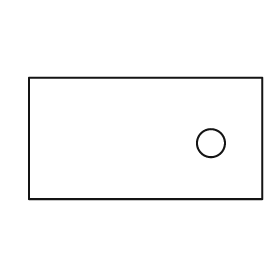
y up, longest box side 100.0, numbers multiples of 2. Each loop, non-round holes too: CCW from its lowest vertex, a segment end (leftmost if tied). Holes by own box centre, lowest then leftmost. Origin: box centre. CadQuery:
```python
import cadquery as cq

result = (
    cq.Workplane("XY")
    .moveTo(-50.0, -26.0)
    .lineTo(50.0, -26.0)
    .lineTo(50.0, 26.0)
    .lineTo(-50.0, 26.0)
    .close()
    .moveTo(28.0, -2.0)
    .circle(6.0)
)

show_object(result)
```